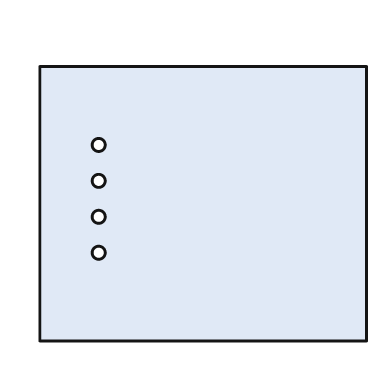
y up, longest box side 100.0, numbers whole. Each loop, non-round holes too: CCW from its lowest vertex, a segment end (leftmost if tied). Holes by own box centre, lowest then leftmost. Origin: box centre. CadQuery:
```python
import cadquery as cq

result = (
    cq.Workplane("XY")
    .moveTo(-50.0, -42.0)
    .lineTo(50.0, -42.0)
    .lineTo(50.0, 42.0)
    .lineTo(-50.0, 42.0)
    .close()
    .moveTo(-32.0, -15.0)
    .circle(2.0)
    .moveTo(-32.0, -4.0)
    .circle(2.0)
    .moveTo(-32.0, 7.0)
    .circle(2.0)
    .moveTo(-32.0, 18.0)
    .circle(2.0)
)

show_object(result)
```